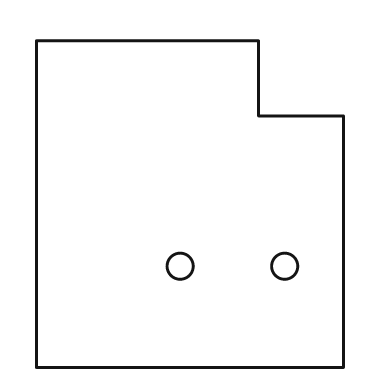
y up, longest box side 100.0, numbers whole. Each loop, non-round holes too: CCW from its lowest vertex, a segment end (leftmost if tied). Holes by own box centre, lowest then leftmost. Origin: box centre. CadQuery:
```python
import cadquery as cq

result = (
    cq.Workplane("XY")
    .moveTo(-47.0, -50.0)
    .lineTo(47.0, -50.0)
    .lineTo(47.0, 27.0)
    .lineTo(21.0, 27.0)
    .lineTo(21.0, 50.0)
    .lineTo(-47.0, 50.0)
    .close()
    .moveTo(-3.0, -19.0)
    .circle(4.0)
    .moveTo(29.0, -19.0)
    .circle(4.0)
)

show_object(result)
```